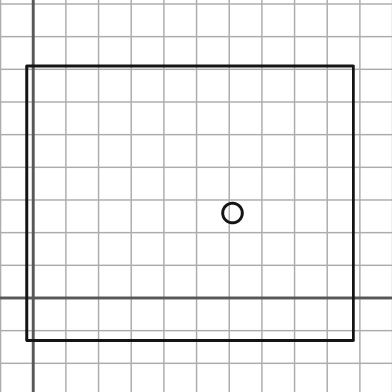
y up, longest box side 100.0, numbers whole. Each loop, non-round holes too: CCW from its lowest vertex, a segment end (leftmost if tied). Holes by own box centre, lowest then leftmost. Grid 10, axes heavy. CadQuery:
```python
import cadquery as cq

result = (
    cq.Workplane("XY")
    .moveTo(-2.0, -13.0)
    .lineTo(98.0, -13.0)
    .lineTo(98.0, 71.0)
    .lineTo(-2.0, 71.0)
    .close()
    .moveTo(61.0, 26.0)
    .circle(3.0)
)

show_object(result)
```